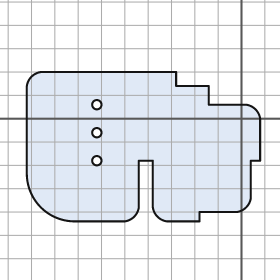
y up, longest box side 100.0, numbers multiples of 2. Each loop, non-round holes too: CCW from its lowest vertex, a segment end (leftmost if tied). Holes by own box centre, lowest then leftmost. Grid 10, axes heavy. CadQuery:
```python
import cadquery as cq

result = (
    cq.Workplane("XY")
    .moveTo(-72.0, -44.0)
    .lineTo(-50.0, -44.0)
    .threePointArc((-46.0, -42.0), (-44.0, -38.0))
    .lineTo(-44.0, -18.0)
    .lineTo(-38.0, -18.0)
    .lineTo(-38.0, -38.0)
    .threePointArc((-36.0, -42.0), (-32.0, -44.0))
    .lineTo(-18.0, -44.0)
    .lineTo(-18.0, -40.0)
    .lineTo(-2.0, -40.0)
    .threePointArc((2.0, -38.0), (4.0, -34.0))
    .lineTo(4.0, -18.0)
    .lineTo(8.0, -18.0)
    .lineTo(8.0, 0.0)
    .threePointArc((6.0, 4.0), (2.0, 6.0))
    .lineTo(-14.0, 6.0)
    .lineTo(-14.0, 14.0)
    .lineTo(-28.0, 14.0)
    .lineTo(-28.0, 20.0)
    .lineTo(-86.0, 20.0)
    .threePointArc((-90.0, 18.0), (-92.0, 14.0))
    .lineTo(-92.0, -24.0)
    .threePointArc((-86.0, -38.0), (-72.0, -44.0))
    .close()
    .moveTo(-62.0, -18.0)
    .circle(2.0)
    .moveTo(-62.0, -6.0)
    .circle(2.0)
    .moveTo(-62.0, 6.0)
    .circle(2.0)
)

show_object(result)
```